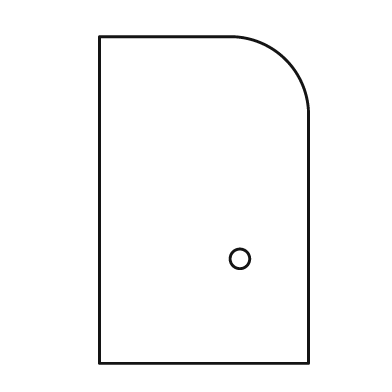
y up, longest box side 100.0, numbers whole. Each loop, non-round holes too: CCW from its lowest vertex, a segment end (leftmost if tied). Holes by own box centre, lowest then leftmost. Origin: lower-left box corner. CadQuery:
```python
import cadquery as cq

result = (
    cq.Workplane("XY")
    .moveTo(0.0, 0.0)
    .lineTo(64.0, 0.0)
    .lineTo(64.0, 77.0)
    .threePointArc((57.0, 93.0), (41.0, 100.0))
    .lineTo(0.0, 100.0)
    .close()
    .moveTo(43.0, 32.0)
    .circle(3.0)
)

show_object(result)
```